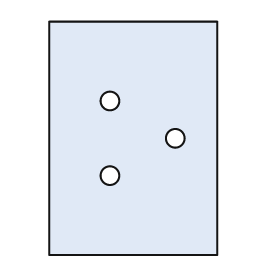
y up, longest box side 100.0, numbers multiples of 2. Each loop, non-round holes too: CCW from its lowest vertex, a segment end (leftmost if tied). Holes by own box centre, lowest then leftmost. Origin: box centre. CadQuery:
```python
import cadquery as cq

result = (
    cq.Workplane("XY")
    .moveTo(-36.0, -50.0)
    .lineTo(36.0, -50.0)
    .lineTo(36.0, 50.0)
    .lineTo(-36.0, 50.0)
    .close()
    .moveTo(-10.0, -16.0)
    .circle(4.0)
    .moveTo(18.0, 0.0)
    .circle(4.0)
    .moveTo(-10.0, 16.0)
    .circle(4.0)
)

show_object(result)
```